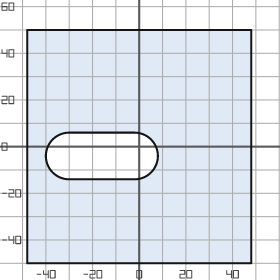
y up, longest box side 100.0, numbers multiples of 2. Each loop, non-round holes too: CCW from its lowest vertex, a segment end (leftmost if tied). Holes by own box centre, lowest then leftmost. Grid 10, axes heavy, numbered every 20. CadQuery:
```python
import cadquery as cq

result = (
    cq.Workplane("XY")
    .moveTo(-48.0, -50.0)
    .lineTo(48.0, -50.0)
    .lineTo(48.0, 50.0)
    .lineTo(-48.0, 50.0)
    .close()
    .moveTo(-30.0, -14.0)
    .lineTo(-2.0, -14.0)
    .threePointArc((8.0, -4.0), (-2.0, 6.0))
    .lineTo(-30.0, 6.0)
    .threePointArc((-40.0, -4.0), (-30.0, -14.0))
    .close()
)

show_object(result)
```